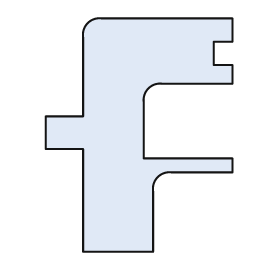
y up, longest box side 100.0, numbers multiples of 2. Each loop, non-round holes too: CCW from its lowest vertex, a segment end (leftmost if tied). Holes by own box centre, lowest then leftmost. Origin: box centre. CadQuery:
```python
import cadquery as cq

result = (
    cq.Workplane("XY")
    .moveTo(-24.0, -50.0)
    .lineTo(6.0, -50.0)
    .lineTo(6.0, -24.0)
    .threePointArc((8.0, -18.0), (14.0, -16.0))
    .lineTo(40.0, -16.0)
    .lineTo(40.0, -10.0)
    .lineTo(2.0, -10.0)
    .lineTo(2.0, 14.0)
    .threePointArc((4.0, 20.0), (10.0, 22.0))
    .lineTo(40.0, 22.0)
    .lineTo(40.0, 30.0)
    .lineTo(32.0, 30.0)
    .lineTo(32.0, 40.0)
    .lineTo(40.0, 40.0)
    .lineTo(40.0, 50.0)
    .lineTo(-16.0, 50.0)
    .threePointArc((-22.0, 48.0), (-24.0, 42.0))
    .lineTo(-24.0, 8.0)
    .lineTo(-40.0, 8.0)
    .lineTo(-40.0, -6.0)
    .lineTo(-24.0, -6.0)
    .close()
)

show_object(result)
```